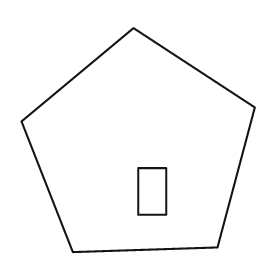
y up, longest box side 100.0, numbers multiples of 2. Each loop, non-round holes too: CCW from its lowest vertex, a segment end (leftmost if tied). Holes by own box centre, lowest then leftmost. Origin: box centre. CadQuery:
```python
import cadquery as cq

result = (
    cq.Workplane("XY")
    .moveTo(-28.0, -48.0)
    .lineTo(34.0, -46.0)
    .lineTo(50.0, 14.0)
    .lineTo(-2.0, 48.0)
    .lineTo(-50.0, 8.0)
    .close()
    .moveTo(0.0, -32.0)
    .lineTo(12.0, -32.0)
    .lineTo(12.0, -12.0)
    .lineTo(0.0, -12.0)
    .close()
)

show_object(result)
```